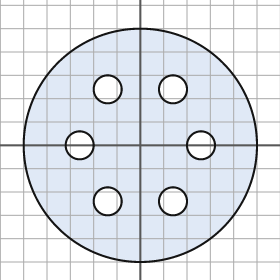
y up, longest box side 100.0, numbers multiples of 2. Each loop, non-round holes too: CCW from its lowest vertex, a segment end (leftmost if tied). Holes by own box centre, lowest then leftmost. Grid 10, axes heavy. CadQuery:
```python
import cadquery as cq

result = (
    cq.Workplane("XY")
    .moveTo(0.0, 0.0)
    .circle(50.0)
    .moveTo(-14.0, -24.0)
    .circle(6.0)
    .moveTo(14.0, -24.0)
    .circle(6.0)
    .moveTo(-26.0, 0.0)
    .circle(6.0)
    .moveTo(26.0, 0.0)
    .circle(6.0)
    .moveTo(-14.0, 24.0)
    .circle(6.0)
    .moveTo(14.0, 24.0)
    .circle(6.0)
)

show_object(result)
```